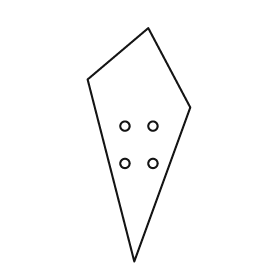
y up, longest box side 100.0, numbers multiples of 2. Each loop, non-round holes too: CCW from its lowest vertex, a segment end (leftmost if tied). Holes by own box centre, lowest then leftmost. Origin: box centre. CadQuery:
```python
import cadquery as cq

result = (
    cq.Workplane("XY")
    .moveTo(-2.0, -50.0)
    .lineTo(22.0, 16.0)
    .lineTo(4.0, 50.0)
    .lineTo(-22.0, 28.0)
    .close()
    .moveTo(-6.0, -8.0)
    .circle(2.0)
    .moveTo(6.0, -8.0)
    .circle(2.0)
    .moveTo(-6.0, 8.0)
    .circle(2.0)
    .moveTo(6.0, 8.0)
    .circle(2.0)
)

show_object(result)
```